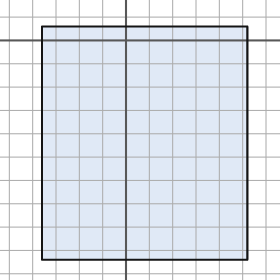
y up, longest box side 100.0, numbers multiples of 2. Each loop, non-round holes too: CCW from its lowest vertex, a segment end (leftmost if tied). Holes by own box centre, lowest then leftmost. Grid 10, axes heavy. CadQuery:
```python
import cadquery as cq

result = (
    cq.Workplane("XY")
    .moveTo(-36.0, -94.0)
    .lineTo(52.0, -94.0)
    .lineTo(52.0, 6.0)
    .lineTo(-36.0, 6.0)
    .close()
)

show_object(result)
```